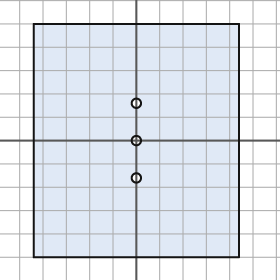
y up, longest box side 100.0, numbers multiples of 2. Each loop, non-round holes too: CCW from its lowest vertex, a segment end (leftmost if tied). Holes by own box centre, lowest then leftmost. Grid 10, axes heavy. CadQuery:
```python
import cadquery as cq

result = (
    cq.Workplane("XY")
    .moveTo(-44.0, -50.0)
    .lineTo(44.0, -50.0)
    .lineTo(44.0, 50.0)
    .lineTo(-44.0, 50.0)
    .close()
    .moveTo(0.0, -16.0)
    .circle(2.0)
    .moveTo(0.0, 0.0)
    .circle(2.0)
    .moveTo(0.0, 16.0)
    .circle(2.0)
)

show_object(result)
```